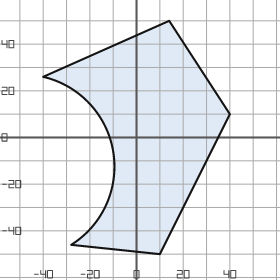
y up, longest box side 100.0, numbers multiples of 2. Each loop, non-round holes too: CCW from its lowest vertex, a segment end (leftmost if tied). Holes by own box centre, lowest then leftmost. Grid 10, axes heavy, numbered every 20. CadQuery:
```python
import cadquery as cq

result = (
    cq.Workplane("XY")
    .moveTo(10.0, -50.0)
    .lineTo(40.0, 10.0)
    .lineTo(14.0, 50.0)
    .lineTo(-40.0, 26.0)
    .threePointArc((-10.0, -6.0), (-28.0, -46.0))
    .close()
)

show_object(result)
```